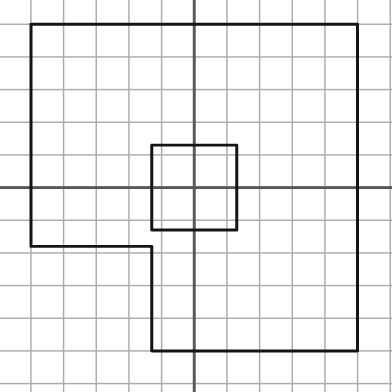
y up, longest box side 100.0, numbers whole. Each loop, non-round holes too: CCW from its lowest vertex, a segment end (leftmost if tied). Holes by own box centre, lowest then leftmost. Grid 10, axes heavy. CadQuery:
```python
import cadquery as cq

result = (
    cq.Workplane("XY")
    .moveTo(-13.0, -50.0)
    .lineTo(50.0, -50.0)
    .lineTo(50.0, 50.0)
    .lineTo(-50.0, 50.0)
    .lineTo(-50.0, -18.0)
    .lineTo(-13.0, -18.0)
    .close()
    .moveTo(-13.0, -13.0)
    .lineTo(13.0, -13.0)
    .lineTo(13.0, 13.0)
    .lineTo(-13.0, 13.0)
    .close()
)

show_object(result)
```